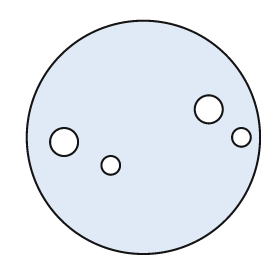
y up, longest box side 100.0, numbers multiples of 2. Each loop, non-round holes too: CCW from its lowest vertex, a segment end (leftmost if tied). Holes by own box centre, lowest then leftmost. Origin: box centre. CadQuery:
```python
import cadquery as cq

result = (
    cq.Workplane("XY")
    .moveTo(0.0, 0.0)
    .circle(50.0)
    .moveTo(-14.0, -12.0)
    .circle(4.0)
    .moveTo(-34.0, -2.0)
    .circle(6.0)
    .moveTo(42.0, 0.0)
    .circle(4.0)
    .moveTo(28.0, 12.0)
    .circle(6.0)
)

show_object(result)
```